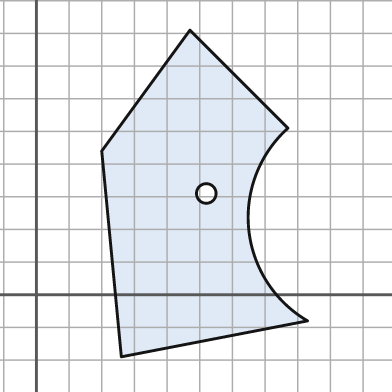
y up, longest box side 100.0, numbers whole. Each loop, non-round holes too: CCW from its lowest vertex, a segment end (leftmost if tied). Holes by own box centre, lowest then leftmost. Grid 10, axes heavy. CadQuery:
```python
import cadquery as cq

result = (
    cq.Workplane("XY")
    .moveTo(26.0, -19.0)
    .lineTo(83.0, -8.0)
    .threePointArc((65.0, 20.0), (77.0, 51.0))
    .lineTo(47.0, 81.0)
    .lineTo(20.0, 44.0)
    .close()
    .moveTo(52.0, 31.0)
    .circle(3.0)
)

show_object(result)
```